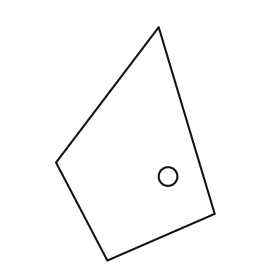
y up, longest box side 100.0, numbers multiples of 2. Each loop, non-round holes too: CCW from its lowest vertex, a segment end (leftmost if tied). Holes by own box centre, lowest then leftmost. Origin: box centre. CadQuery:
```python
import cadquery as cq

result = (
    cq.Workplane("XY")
    .moveTo(-12.0, -50.0)
    .lineTo(34.0, -30.0)
    .lineTo(10.0, 50.0)
    .lineTo(-34.0, -8.0)
    .close()
    .moveTo(14.0, -14.0)
    .circle(4.0)
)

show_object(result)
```